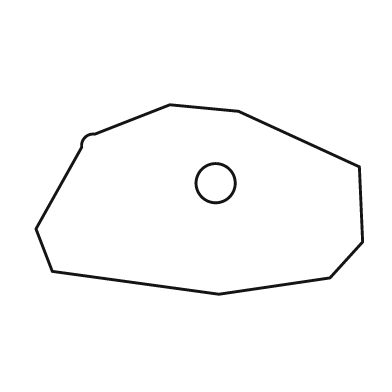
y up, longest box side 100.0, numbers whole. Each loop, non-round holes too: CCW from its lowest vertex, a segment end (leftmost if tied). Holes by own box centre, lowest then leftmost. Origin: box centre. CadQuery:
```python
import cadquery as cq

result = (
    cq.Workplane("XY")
    .moveTo(6.0, -29.0)
    .lineTo(40.0, -24.0)
    .lineTo(50.0, -13.0)
    .lineTo(49.0, 10.0)
    .lineTo(12.0, 27.0)
    .lineTo(-9.0, 29.0)
    .lineTo(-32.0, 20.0)
    .threePointArc((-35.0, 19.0), (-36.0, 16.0))
    .lineTo(-50.0, -9.0)
    .lineTo(-45.0, -22.0)
    .close()
    .moveTo(5.0, 5.0)
    .circle(6.0)
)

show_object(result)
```